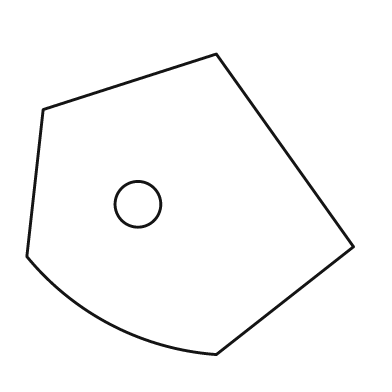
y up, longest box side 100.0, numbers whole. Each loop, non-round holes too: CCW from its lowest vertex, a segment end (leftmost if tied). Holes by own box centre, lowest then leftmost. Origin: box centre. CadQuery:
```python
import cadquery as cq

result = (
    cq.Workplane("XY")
    .moveTo(8.0, -46.0)
    .lineTo(50.0, -13.0)
    .lineTo(8.0, 46.0)
    .lineTo(-45.0, 29.0)
    .lineTo(-50.0, -16.0)
    .threePointArc((-24.0, -37.0), (8.0, -46.0))
    .close()
    .moveTo(-16.0, 0.0)
    .circle(7.0)
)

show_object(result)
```